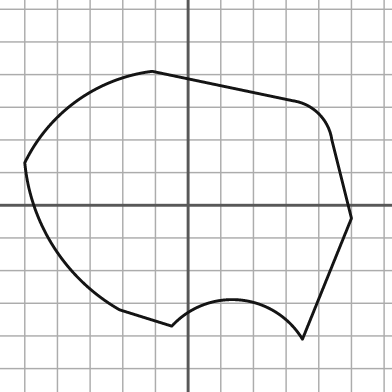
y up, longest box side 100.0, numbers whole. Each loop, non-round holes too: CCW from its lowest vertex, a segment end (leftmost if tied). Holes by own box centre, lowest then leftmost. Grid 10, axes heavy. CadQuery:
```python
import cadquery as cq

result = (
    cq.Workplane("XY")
    .moveTo(35.0, -41.0)
    .lineTo(50.0, -4.0)
    .lineTo(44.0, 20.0)
    .threePointArc((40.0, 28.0), (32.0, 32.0))
    .lineTo(-11.0, 41.0)
    .threePointArc((-34.0, 32.0), (-50.0, 13.0))
    .threePointArc((-41.0, -13.0), (-21.0, -32.0))
    .lineTo(-5.0, -37.0)
    .threePointArc((16.0, -29.0), (35.0, -41.0))
    .close()
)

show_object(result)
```